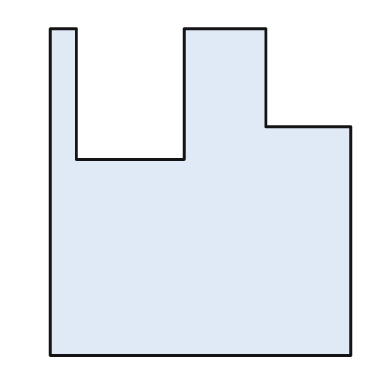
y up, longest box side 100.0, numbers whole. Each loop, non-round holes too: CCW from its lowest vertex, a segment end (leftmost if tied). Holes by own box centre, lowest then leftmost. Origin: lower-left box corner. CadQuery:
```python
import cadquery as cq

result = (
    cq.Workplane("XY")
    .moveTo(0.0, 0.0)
    .lineTo(92.0, 0.0)
    .lineTo(92.0, 70.0)
    .lineTo(66.0, 70.0)
    .lineTo(66.0, 100.0)
    .lineTo(41.0, 100.0)
    .lineTo(41.0, 60.0)
    .lineTo(8.0, 60.0)
    .lineTo(8.0, 100.0)
    .lineTo(0.0, 100.0)
    .close()
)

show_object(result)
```